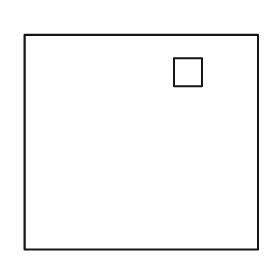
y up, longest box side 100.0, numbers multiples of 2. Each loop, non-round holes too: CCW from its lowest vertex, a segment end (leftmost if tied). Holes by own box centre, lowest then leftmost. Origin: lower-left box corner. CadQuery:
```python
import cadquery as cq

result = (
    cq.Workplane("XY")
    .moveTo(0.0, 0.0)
    .lineTo(100.0, 0.0)
    .lineTo(100.0, 92.0)
    .lineTo(0.0, 92.0)
    .close()
    .moveTo(64.0, 70.0)
    .lineTo(76.0, 70.0)
    .lineTo(76.0, 82.0)
    .lineTo(64.0, 82.0)
    .close()
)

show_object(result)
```